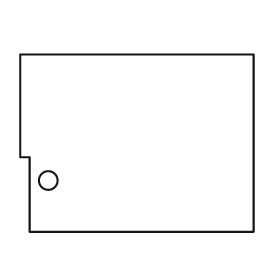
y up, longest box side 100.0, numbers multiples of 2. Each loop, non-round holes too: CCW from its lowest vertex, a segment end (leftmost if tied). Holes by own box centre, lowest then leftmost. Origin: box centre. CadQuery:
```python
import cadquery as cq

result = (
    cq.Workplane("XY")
    .moveTo(-46.0, -38.0)
    .lineTo(50.0, -38.0)
    .lineTo(50.0, 38.0)
    .lineTo(-50.0, 38.0)
    .lineTo(-50.0, -6.0)
    .lineTo(-46.0, -6.0)
    .close()
    .moveTo(-38.0, -16.0)
    .circle(4.0)
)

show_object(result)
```